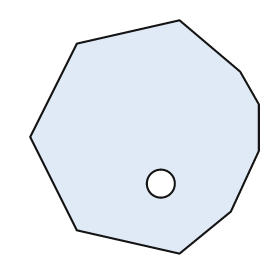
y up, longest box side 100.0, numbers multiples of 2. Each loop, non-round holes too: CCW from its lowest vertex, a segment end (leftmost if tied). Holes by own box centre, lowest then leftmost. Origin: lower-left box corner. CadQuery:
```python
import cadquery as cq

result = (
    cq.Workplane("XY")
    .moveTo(64.0, 0.0)
    .lineTo(86.0, 18.0)
    .lineTo(98.0, 44.0)
    .lineTo(98.0, 64.0)
    .lineTo(90.0, 78.0)
    .lineTo(64.0, 100.0)
    .lineTo(20.0, 90.0)
    .lineTo(0.0, 50.0)
    .lineTo(20.0, 10.0)
    .close()
    .moveTo(56.0, 30.0)
    .circle(6.0)
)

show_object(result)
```